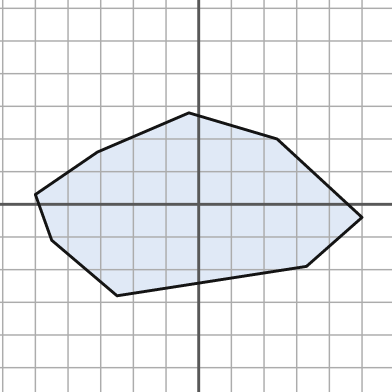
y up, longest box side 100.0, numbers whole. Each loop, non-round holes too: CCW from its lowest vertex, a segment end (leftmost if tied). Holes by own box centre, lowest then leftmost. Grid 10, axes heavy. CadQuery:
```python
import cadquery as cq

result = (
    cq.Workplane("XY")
    .moveTo(-25.0, -28.0)
    .lineTo(33.0, -19.0)
    .lineTo(50.0, -4.0)
    .lineTo(24.0, 20.0)
    .lineTo(-3.0, 28.0)
    .lineTo(-31.0, 16.0)
    .lineTo(-50.0, 3.0)
    .lineTo(-45.0, -11.0)
    .close()
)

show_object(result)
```